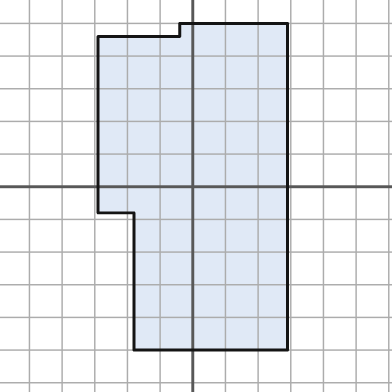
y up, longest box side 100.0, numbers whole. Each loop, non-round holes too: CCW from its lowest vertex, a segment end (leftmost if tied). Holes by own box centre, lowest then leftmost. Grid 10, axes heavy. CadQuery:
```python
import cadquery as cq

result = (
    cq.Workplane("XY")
    .moveTo(-18.0, -50.0)
    .lineTo(29.0, -50.0)
    .lineTo(29.0, 50.0)
    .lineTo(-4.0, 50.0)
    .lineTo(-4.0, 46.0)
    .lineTo(-29.0, 46.0)
    .lineTo(-29.0, -8.0)
    .lineTo(-18.0, -8.0)
    .close()
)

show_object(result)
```